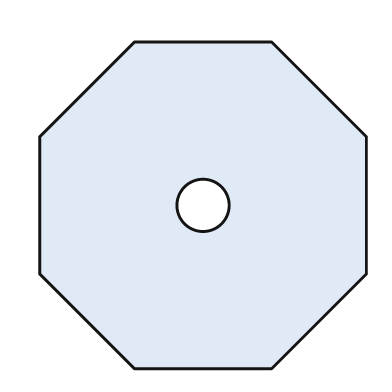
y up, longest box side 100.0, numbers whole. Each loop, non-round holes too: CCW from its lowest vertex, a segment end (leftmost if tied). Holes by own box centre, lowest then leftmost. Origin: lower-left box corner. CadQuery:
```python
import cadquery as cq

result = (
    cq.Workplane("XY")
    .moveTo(29.0, 0.0)
    .lineTo(71.0, 0.0)
    .lineTo(100.0, 29.0)
    .lineTo(100.0, 71.0)
    .lineTo(71.0, 100.0)
    .lineTo(29.0, 100.0)
    .lineTo(0.0, 71.0)
    .lineTo(0.0, 29.0)
    .close()
    .moveTo(50.0, 50.0)
    .circle(8.0)
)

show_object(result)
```